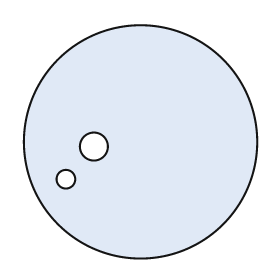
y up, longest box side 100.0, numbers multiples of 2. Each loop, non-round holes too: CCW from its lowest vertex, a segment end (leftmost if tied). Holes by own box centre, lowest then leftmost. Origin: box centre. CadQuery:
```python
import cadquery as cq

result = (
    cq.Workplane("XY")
    .moveTo(0.0, 0.0)
    .circle(50.0)
    .moveTo(-32.0, -16.0)
    .circle(4.0)
    .moveTo(-20.0, -2.0)
    .circle(6.0)
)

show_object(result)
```